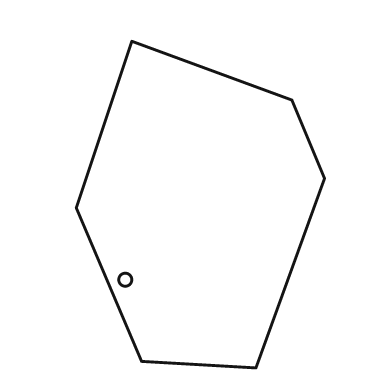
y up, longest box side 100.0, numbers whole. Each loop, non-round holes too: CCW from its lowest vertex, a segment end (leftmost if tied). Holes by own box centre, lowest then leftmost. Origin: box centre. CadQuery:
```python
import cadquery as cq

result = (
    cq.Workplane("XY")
    .moveTo(17.0, -50.0)
    .lineTo(38.0, 8.0)
    .lineTo(28.0, 32.0)
    .lineTo(-21.0, 50.0)
    .lineTo(-38.0, -1.0)
    .lineTo(-18.0, -48.0)
    .close()
    .moveTo(-23.0, -23.0)
    .circle(2.0)
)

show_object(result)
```